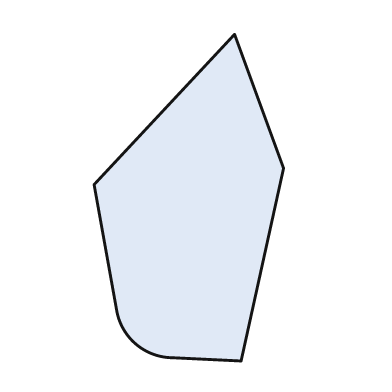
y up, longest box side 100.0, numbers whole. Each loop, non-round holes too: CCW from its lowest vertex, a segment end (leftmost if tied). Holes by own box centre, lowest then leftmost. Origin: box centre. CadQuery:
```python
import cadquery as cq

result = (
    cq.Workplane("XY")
    .moveTo(16.0, -50.0)
    .lineTo(29.0, 9.0)
    .lineTo(14.0, 50.0)
    .lineTo(-29.0, 4.0)
    .lineTo(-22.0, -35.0)
    .threePointArc((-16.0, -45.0), (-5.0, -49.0))
    .close()
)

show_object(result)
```